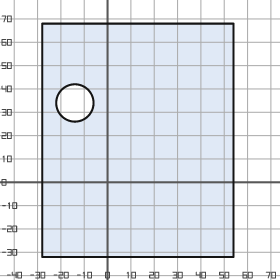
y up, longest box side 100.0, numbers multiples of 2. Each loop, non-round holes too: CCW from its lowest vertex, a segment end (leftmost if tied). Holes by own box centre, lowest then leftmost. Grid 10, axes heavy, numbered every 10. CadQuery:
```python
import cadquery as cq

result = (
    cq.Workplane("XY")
    .moveTo(-28.0, -32.0)
    .lineTo(54.0, -32.0)
    .lineTo(54.0, 68.0)
    .lineTo(-28.0, 68.0)
    .close()
    .moveTo(-14.0, 34.0)
    .circle(8.0)
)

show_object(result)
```